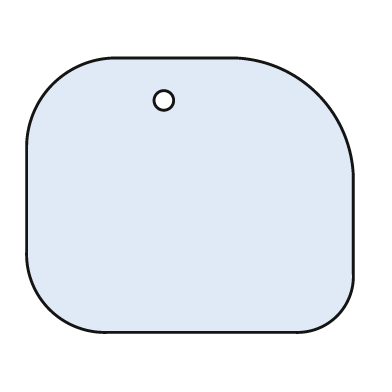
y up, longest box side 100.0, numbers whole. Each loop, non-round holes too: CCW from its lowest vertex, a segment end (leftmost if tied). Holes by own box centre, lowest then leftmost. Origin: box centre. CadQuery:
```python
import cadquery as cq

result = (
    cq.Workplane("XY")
    .moveTo(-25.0, -42.0)
    .lineTo(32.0, -42.0)
    .threePointArc((45.0, -37.0), (50.0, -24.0))
    .lineTo(50.0, 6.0)
    .threePointArc((39.0, 31.0), (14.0, 42.0))
    .lineTo(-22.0, 42.0)
    .threePointArc((-42.0, 34.0), (-50.0, 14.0))
    .lineTo(-50.0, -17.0)
    .threePointArc((-43.0, -35.0), (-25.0, -42.0))
    .close()
    .moveTo(-8.0, 29.0)
    .circle(3.0)
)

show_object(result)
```